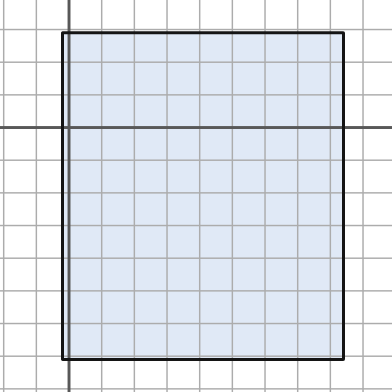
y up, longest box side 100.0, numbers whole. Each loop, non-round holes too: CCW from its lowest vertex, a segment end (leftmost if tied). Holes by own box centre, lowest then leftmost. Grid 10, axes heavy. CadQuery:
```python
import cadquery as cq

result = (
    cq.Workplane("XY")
    .moveTo(-2.0, -71.0)
    .lineTo(84.0, -71.0)
    .lineTo(84.0, 29.0)
    .lineTo(-2.0, 29.0)
    .close()
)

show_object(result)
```